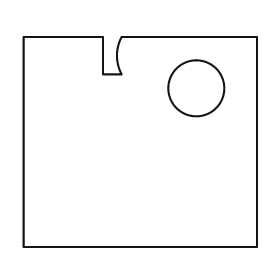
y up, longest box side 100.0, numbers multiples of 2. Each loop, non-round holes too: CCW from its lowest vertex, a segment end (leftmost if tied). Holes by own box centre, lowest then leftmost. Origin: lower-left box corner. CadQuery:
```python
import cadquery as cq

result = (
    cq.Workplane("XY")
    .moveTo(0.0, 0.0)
    .lineTo(100.0, 0.0)
    .lineTo(100.0, 90.0)
    .lineTo(42.0, 90.0)
    .threePointArc((40.0, 82.0), (42.0, 74.0))
    .lineTo(34.0, 74.0)
    .lineTo(34.0, 90.0)
    .lineTo(0.0, 90.0)
    .close()
    .moveTo(74.0, 68.0)
    .circle(12.0)
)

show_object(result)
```